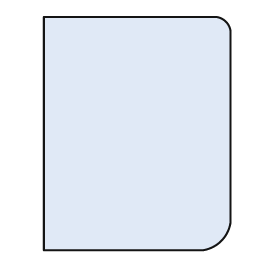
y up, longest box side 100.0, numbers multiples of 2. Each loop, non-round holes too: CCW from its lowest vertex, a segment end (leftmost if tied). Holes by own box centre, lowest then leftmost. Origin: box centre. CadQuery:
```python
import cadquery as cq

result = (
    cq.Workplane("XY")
    .moveTo(-40.0, -50.0)
    .lineTo(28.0, -50.0)
    .threePointArc((36.0, -46.0), (40.0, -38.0))
    .lineTo(40.0, 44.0)
    .threePointArc((38.0, 48.0), (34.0, 50.0))
    .lineTo(-40.0, 50.0)
    .close()
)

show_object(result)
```